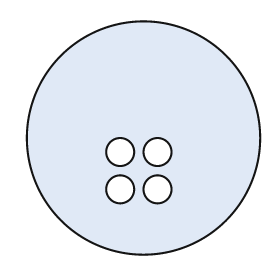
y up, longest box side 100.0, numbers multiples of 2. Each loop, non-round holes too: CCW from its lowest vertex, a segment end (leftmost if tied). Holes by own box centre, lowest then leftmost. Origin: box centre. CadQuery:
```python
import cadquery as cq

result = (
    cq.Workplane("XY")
    .moveTo(0.0, 0.0)
    .circle(50.0)
    .moveTo(-10.0, -22.0)
    .circle(6.0)
    .moveTo(6.0, -22.0)
    .circle(6.0)
    .moveTo(-10.0, -6.0)
    .circle(6.0)
    .moveTo(6.0, -6.0)
    .circle(6.0)
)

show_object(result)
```